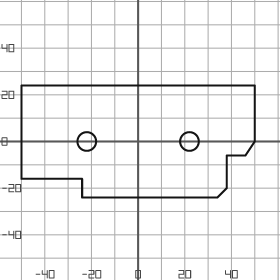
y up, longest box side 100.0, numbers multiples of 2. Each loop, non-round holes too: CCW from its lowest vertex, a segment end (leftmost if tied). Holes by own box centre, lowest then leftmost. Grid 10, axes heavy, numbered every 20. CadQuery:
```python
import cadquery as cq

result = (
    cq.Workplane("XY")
    .moveTo(-24.0, -24.0)
    .lineTo(34.0, -24.0)
    .lineTo(38.0, -20.0)
    .lineTo(38.0, -6.0)
    .lineTo(46.0, -6.0)
    .lineTo(50.0, 0.0)
    .lineTo(50.0, 24.0)
    .lineTo(-50.0, 24.0)
    .lineTo(-50.0, -16.0)
    .lineTo(-24.0, -16.0)
    .close()
    .moveTo(-22.0, 0.0)
    .circle(4.0)
    .moveTo(22.0, 0.0)
    .circle(4.0)
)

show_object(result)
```